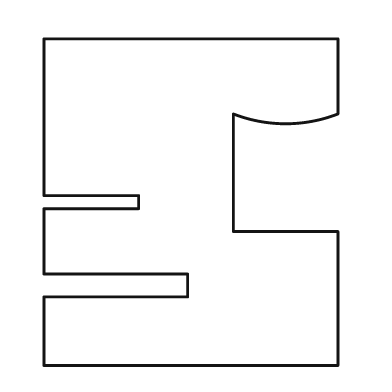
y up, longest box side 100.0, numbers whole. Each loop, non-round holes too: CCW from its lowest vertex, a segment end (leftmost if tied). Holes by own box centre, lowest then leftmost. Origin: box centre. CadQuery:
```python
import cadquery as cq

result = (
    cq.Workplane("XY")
    .moveTo(-45.0, -50.0)
    .lineTo(45.0, -50.0)
    .lineTo(45.0, -9.0)
    .lineTo(13.0, -9.0)
    .lineTo(13.0, 27.0)
    .threePointArc((29.0, 24.0), (45.0, 27.0))
    .lineTo(45.0, 50.0)
    .lineTo(-45.0, 50.0)
    .lineTo(-45.0, 2.0)
    .lineTo(-16.0, 2.0)
    .lineTo(-16.0, -2.0)
    .lineTo(-45.0, -2.0)
    .lineTo(-45.0, -22.0)
    .lineTo(-1.0, -22.0)
    .lineTo(-1.0, -29.0)
    .lineTo(-45.0, -29.0)
    .close()
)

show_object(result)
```